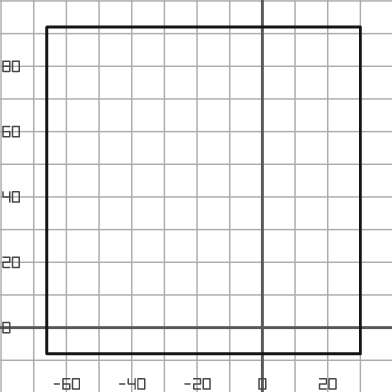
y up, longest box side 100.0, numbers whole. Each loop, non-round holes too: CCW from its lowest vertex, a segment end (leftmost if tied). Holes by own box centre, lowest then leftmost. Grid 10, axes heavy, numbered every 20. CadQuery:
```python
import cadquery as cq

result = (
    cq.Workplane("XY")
    .moveTo(-66.0, -8.0)
    .lineTo(30.0, -8.0)
    .lineTo(30.0, 92.0)
    .lineTo(-66.0, 92.0)
    .close()
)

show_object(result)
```